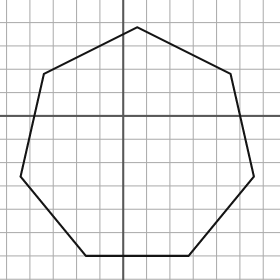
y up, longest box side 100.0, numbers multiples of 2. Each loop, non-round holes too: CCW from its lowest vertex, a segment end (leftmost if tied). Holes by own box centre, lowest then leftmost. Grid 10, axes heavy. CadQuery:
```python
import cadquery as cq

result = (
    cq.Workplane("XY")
    .moveTo(-16.0, -60.0)
    .lineTo(28.0, -60.0)
    .lineTo(56.0, -26.0)
    .lineTo(46.0, 18.0)
    .lineTo(6.0, 38.0)
    .lineTo(-34.0, 18.0)
    .lineTo(-44.0, -26.0)
    .close()
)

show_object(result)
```